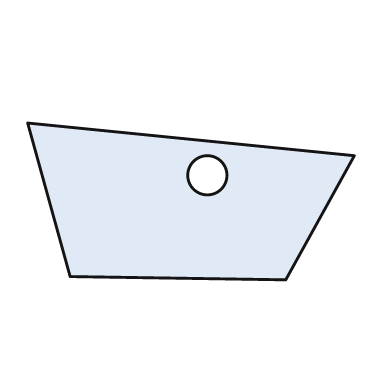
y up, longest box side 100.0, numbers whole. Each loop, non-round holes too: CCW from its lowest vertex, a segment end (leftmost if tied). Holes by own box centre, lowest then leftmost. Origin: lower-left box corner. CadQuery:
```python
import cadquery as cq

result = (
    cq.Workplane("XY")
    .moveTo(79.0, 0.0)
    .lineTo(100.0, 38.0)
    .lineTo(0.0, 48.0)
    .lineTo(13.0, 1.0)
    .close()
    .moveTo(55.0, 32.0)
    .circle(6.0)
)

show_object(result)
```